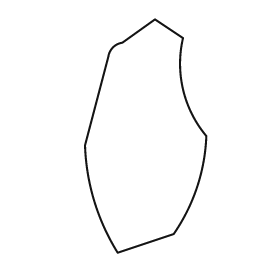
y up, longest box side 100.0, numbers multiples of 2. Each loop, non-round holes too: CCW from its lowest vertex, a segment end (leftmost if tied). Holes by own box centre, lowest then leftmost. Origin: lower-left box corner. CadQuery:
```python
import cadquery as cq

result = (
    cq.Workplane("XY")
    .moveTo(14.0, 0.0)
    .lineTo(38.0, 8.0)
    .threePointArc((48.0, 28.0), (52.0, 50.0))
    .threePointArc((42.0, 70.0), (42.0, 92.0))
    .lineTo(30.0, 100.0)
    .lineTo(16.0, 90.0)
    .threePointArc((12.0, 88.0), (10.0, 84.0))
    .lineTo(0.0, 46.0)
    .threePointArc((4.0, 22.0), (14.0, 0.0))
    .close()
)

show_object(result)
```